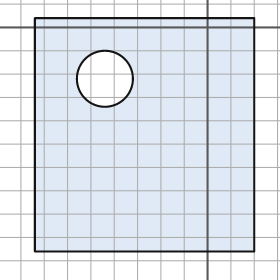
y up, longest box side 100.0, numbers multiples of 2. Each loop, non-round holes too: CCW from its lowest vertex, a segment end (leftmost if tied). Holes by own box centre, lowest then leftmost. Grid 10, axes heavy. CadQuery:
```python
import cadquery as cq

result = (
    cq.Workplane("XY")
    .moveTo(-74.0, -96.0)
    .lineTo(20.0, -96.0)
    .lineTo(20.0, 4.0)
    .lineTo(-74.0, 4.0)
    .close()
    .moveTo(-44.0, -22.0)
    .circle(12.0)
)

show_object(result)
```